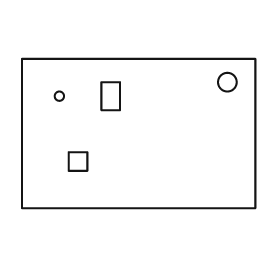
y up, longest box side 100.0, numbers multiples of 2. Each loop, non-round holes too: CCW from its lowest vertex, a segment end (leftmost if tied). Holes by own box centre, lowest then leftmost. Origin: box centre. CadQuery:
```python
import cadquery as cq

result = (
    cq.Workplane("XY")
    .moveTo(-50.0, -32.0)
    .lineTo(50.0, -32.0)
    .lineTo(50.0, 32.0)
    .lineTo(-50.0, 32.0)
    .close()
    .moveTo(-30.0, -16.0)
    .lineTo(-22.0, -16.0)
    .lineTo(-22.0, -8.0)
    .lineTo(-30.0, -8.0)
    .close()
    .moveTo(-34.0, 16.0)
    .circle(2.0)
    .moveTo(-16.0, 10.0)
    .lineTo(-8.0, 10.0)
    .lineTo(-8.0, 22.0)
    .lineTo(-16.0, 22.0)
    .close()
    .moveTo(38.0, 22.0)
    .circle(4.0)
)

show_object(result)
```